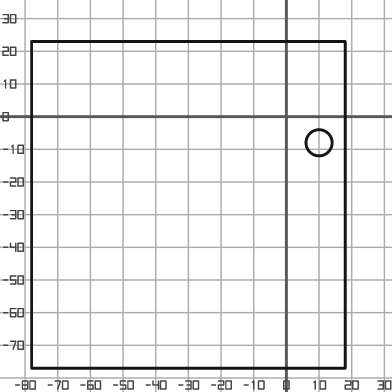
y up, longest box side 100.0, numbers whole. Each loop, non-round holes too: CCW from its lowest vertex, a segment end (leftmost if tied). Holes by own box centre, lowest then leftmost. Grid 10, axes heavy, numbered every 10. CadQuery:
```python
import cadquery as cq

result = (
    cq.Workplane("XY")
    .moveTo(-78.0, -77.0)
    .lineTo(18.0, -77.0)
    .lineTo(18.0, 23.0)
    .lineTo(-78.0, 23.0)
    .close()
    .moveTo(10.0, -8.0)
    .circle(4.0)
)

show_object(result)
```